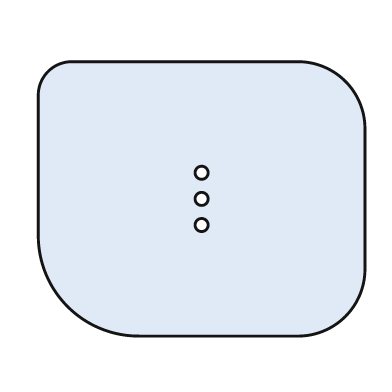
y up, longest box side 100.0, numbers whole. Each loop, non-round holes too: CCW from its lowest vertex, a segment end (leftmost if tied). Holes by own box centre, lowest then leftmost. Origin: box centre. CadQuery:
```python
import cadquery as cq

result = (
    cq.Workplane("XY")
    .moveTo(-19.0, -42.0)
    .lineTo(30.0, -42.0)
    .threePointArc((44.0, -36.0), (50.0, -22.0))
    .lineTo(50.0, 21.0)
    .threePointArc((44.0, 36.0), (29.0, 42.0))
    .lineTo(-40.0, 42.0)
    .threePointArc((-47.0, 39.0), (-50.0, 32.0))
    .lineTo(-50.0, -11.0)
    .threePointArc((-41.0, -33.0), (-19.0, -42.0))
    .close()
    .moveTo(0.0, -8.0)
    .circle(2.0)
    .moveTo(0.0, 0.0)
    .circle(2.0)
    .moveTo(0.0, 8.0)
    .circle(2.0)
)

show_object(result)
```